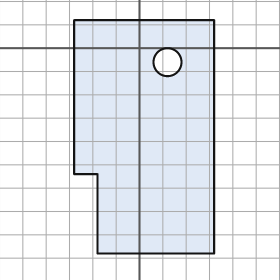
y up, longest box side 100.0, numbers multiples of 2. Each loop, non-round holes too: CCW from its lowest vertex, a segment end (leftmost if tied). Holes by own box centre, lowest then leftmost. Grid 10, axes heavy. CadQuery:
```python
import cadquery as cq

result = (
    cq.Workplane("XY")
    .moveTo(-18.0, -88.0)
    .lineTo(32.0, -88.0)
    .lineTo(32.0, 12.0)
    .lineTo(-28.0, 12.0)
    .lineTo(-28.0, -54.0)
    .lineTo(-18.0, -54.0)
    .close()
    .moveTo(12.0, -6.0)
    .circle(6.0)
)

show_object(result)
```